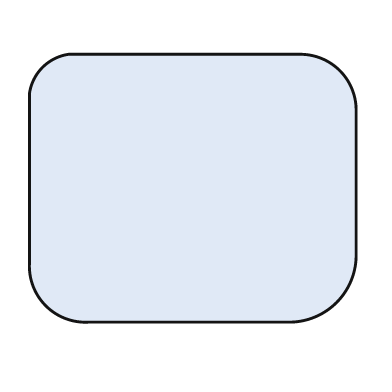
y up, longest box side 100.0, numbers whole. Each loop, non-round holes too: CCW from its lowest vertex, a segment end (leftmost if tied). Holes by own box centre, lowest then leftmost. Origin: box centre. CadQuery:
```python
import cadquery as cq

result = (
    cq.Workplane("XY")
    .moveTo(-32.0, -41.0)
    .lineTo(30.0, -41.0)
    .threePointArc((44.0, -35.0), (50.0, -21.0))
    .lineTo(50.0, 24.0)
    .threePointArc((45.0, 36.0), (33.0, 41.0))
    .lineTo(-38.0, 41.0)
    .threePointArc((-46.0, 37.0), (-50.0, 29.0))
    .lineTo(-50.0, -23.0)
    .threePointArc((-45.0, -36.0), (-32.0, -41.0))
    .close()
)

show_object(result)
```